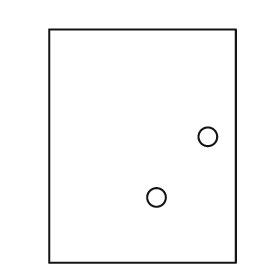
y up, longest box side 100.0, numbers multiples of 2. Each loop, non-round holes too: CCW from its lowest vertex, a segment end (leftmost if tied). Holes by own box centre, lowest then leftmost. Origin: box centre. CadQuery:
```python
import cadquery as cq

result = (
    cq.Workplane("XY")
    .moveTo(-40.0, -50.0)
    .lineTo(40.0, -50.0)
    .lineTo(40.0, 50.0)
    .lineTo(-40.0, 50.0)
    .close()
    .moveTo(6.0, -22.0)
    .circle(4.0)
    .moveTo(28.0, 4.0)
    .circle(4.0)
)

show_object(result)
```